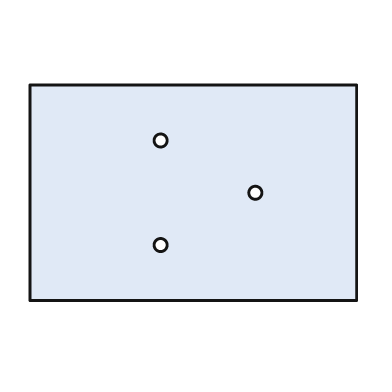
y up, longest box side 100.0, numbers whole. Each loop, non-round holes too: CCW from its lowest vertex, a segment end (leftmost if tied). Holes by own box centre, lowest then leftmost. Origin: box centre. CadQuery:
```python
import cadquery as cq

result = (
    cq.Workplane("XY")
    .moveTo(-50.0, -33.0)
    .lineTo(50.0, -33.0)
    .lineTo(50.0, 33.0)
    .lineTo(-50.0, 33.0)
    .close()
    .moveTo(-10.0, -16.0)
    .circle(2.0)
    .moveTo(19.0, 0.0)
    .circle(2.0)
    .moveTo(-10.0, 16.0)
    .circle(2.0)
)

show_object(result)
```